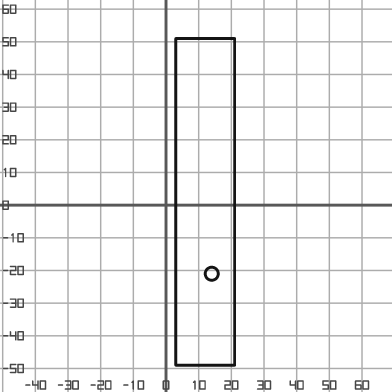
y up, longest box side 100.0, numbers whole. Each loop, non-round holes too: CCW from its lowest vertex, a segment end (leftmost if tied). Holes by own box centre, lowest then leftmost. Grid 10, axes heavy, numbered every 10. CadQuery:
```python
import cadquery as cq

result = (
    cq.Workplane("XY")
    .moveTo(3.0, -49.0)
    .lineTo(21.0, -49.0)
    .lineTo(21.0, 51.0)
    .lineTo(3.0, 51.0)
    .close()
    .moveTo(14.0, -21.0)
    .circle(2.0)
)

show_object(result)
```